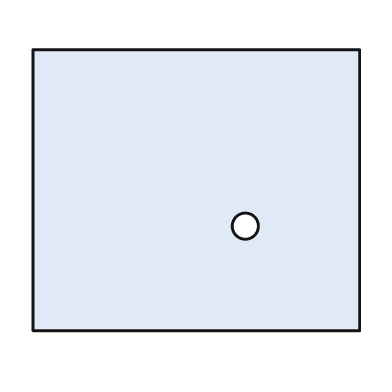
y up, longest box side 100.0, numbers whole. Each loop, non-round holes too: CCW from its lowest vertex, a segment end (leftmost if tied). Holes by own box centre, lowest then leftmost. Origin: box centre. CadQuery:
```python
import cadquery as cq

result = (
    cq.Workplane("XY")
    .moveTo(-50.0, -43.0)
    .lineTo(50.0, -43.0)
    .lineTo(50.0, 43.0)
    .lineTo(-50.0, 43.0)
    .close()
    .moveTo(15.0, -11.0)
    .circle(4.0)
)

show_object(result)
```